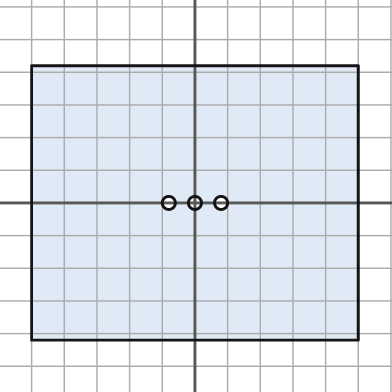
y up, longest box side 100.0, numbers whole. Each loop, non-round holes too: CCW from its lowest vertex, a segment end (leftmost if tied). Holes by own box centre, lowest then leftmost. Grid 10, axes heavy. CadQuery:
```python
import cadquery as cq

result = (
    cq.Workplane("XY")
    .moveTo(-50.0, -42.0)
    .lineTo(50.0, -42.0)
    .lineTo(50.0, 42.0)
    .lineTo(-50.0, 42.0)
    .close()
    .moveTo(-8.0, 0.0)
    .circle(2.0)
    .moveTo(0.0, 0.0)
    .circle(2.0)
    .moveTo(8.0, 0.0)
    .circle(2.0)
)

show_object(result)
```